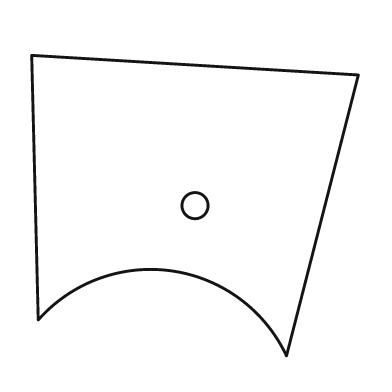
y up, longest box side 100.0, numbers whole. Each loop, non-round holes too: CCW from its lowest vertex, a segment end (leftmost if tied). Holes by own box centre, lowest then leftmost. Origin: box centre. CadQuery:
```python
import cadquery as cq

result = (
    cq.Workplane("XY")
    .moveTo(28.0, -46.0)
    .lineTo(50.0, 40.0)
    .lineTo(-50.0, 46.0)
    .lineTo(-48.0, -35.0)
    .threePointArc((-7.0, -20.0), (28.0, -46.0))
    .close()
    .moveTo(0.0, 0.0)
    .circle(4.0)
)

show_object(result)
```